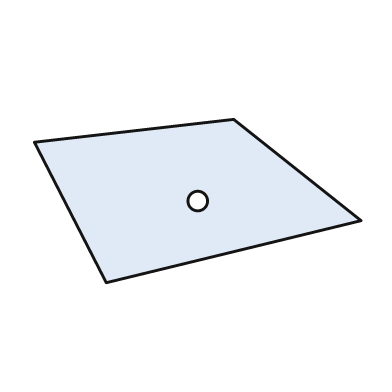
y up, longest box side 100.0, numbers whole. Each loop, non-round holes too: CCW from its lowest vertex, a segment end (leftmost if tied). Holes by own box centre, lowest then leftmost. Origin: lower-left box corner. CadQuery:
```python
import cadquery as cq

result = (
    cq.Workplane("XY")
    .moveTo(22.0, 0.0)
    .lineTo(100.0, 19.0)
    .lineTo(61.0, 50.0)
    .lineTo(0.0, 43.0)
    .close()
    .moveTo(50.0, 25.0)
    .circle(3.0)
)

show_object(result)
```